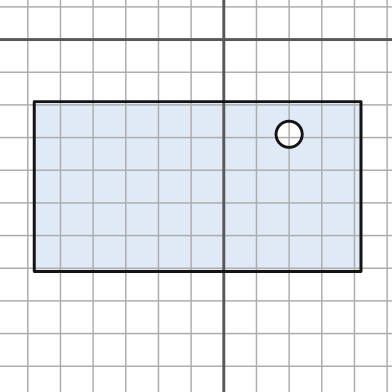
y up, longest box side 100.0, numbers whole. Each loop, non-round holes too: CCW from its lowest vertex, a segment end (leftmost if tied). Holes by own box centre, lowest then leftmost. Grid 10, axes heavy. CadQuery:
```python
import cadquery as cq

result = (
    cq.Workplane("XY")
    .moveTo(-58.0, -71.0)
    .lineTo(42.0, -71.0)
    .lineTo(42.0, -19.0)
    .lineTo(-58.0, -19.0)
    .close()
    .moveTo(20.0, -29.0)
    .circle(4.0)
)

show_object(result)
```